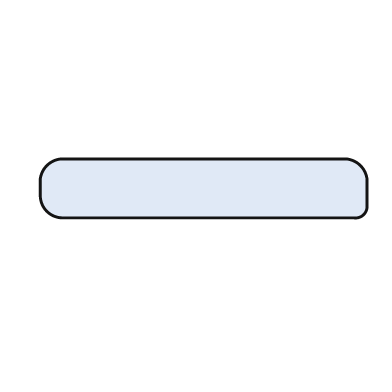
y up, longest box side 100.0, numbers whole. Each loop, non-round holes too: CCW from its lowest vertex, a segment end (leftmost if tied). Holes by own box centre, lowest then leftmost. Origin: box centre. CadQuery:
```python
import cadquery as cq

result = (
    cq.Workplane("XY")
    .moveTo(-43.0, -9.0)
    .lineTo(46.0, -9.0)
    .threePointArc((49.0, -8.0), (50.0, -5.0))
    .lineTo(50.0, 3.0)
    .threePointArc((48.0, 7.0), (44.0, 9.0))
    .lineTo(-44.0, 9.0)
    .threePointArc((-48.0, 7.0), (-50.0, 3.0))
    .lineTo(-50.0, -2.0)
    .threePointArc((-48.0, -7.0), (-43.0, -9.0))
    .close()
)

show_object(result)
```